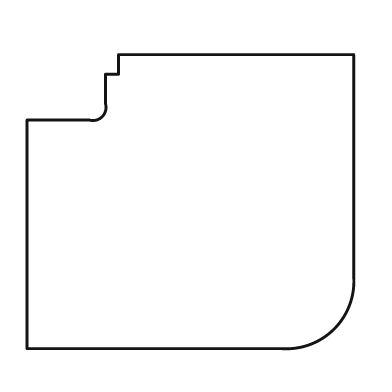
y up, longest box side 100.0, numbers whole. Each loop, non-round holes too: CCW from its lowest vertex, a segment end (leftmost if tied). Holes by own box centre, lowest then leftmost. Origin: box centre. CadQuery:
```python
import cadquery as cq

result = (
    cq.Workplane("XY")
    .moveTo(-50.0, -45.0)
    .lineTo(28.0, -45.0)
    .threePointArc((44.0, -39.0), (50.0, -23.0))
    .lineTo(50.0, 45.0)
    .lineTo(-22.0, 45.0)
    .lineTo(-22.0, 39.0)
    .lineTo(-26.0, 39.0)
    .lineTo(-26.0, 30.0)
    .threePointArc((-27.0, 26.0), (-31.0, 25.0))
    .lineTo(-50.0, 25.0)
    .close()
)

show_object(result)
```